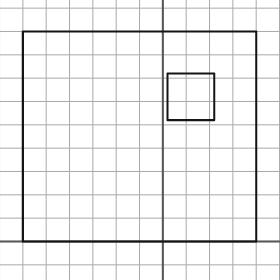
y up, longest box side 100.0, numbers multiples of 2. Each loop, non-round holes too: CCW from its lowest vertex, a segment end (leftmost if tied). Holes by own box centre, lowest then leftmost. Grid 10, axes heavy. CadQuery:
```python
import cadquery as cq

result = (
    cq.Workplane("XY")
    .moveTo(-60.0, 0.0)
    .lineTo(40.0, 0.0)
    .lineTo(40.0, 90.0)
    .lineTo(-60.0, 90.0)
    .close()
    .moveTo(2.0, 52.0)
    .lineTo(22.0, 52.0)
    .lineTo(22.0, 72.0)
    .lineTo(2.0, 72.0)
    .close()
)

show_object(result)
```